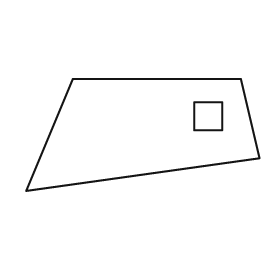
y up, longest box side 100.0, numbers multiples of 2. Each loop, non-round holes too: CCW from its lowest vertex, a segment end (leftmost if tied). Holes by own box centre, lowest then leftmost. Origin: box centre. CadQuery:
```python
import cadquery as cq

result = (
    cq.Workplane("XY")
    .moveTo(-50.0, -24.0)
    .lineTo(50.0, -10.0)
    .lineTo(42.0, 24.0)
    .lineTo(-30.0, 24.0)
    .close()
    .moveTo(22.0, 2.0)
    .lineTo(34.0, 2.0)
    .lineTo(34.0, 14.0)
    .lineTo(22.0, 14.0)
    .close()
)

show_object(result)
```